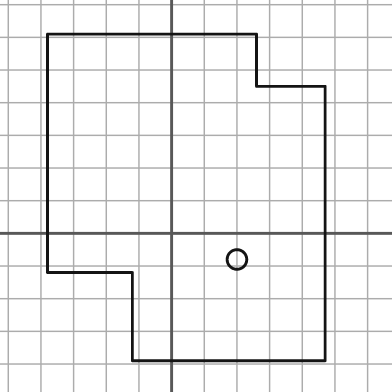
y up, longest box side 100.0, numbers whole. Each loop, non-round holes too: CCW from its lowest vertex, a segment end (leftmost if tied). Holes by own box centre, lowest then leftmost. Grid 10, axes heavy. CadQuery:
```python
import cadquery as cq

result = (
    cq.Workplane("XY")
    .moveTo(-12.0, -39.0)
    .lineTo(47.0, -39.0)
    .lineTo(47.0, 45.0)
    .lineTo(26.0, 45.0)
    .lineTo(26.0, 61.0)
    .lineTo(-38.0, 61.0)
    .lineTo(-38.0, -12.0)
    .lineTo(-12.0, -12.0)
    .close()
    .moveTo(20.0, -8.0)
    .circle(3.0)
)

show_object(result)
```